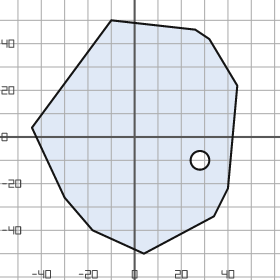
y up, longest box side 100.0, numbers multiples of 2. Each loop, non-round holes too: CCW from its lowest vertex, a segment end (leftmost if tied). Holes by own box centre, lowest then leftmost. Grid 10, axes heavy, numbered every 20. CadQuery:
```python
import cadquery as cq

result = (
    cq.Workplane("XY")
    .moveTo(4.0, -50.0)
    .lineTo(34.0, -34.0)
    .lineTo(40.0, -22.0)
    .lineTo(44.0, 22.0)
    .lineTo(32.0, 42.0)
    .lineTo(26.0, 46.0)
    .lineTo(-10.0, 50.0)
    .lineTo(-44.0, 4.0)
    .lineTo(-30.0, -26.0)
    .lineTo(-18.0, -40.0)
    .close()
    .moveTo(28.0, -10.0)
    .circle(4.0)
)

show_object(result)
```